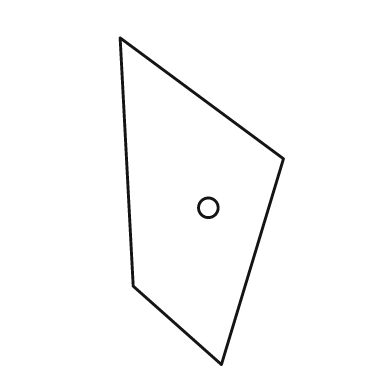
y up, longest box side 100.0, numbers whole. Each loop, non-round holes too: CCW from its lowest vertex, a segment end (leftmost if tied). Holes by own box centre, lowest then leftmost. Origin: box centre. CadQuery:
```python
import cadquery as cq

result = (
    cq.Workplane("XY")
    .moveTo(6.0, -50.0)
    .lineTo(25.0, 13.0)
    .lineTo(-25.0, 50.0)
    .lineTo(-21.0, -26.0)
    .close()
    .moveTo(2.0, -2.0)
    .circle(3.0)
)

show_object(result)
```